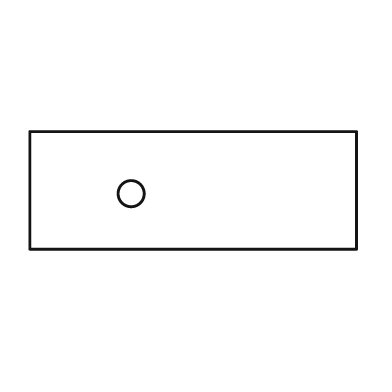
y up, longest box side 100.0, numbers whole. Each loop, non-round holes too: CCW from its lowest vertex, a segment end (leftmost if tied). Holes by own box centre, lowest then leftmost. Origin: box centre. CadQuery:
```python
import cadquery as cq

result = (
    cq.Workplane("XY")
    .moveTo(-50.0, -18.0)
    .lineTo(50.0, -18.0)
    .lineTo(50.0, 18.0)
    .lineTo(-50.0, 18.0)
    .close()
    .moveTo(-19.0, -1.0)
    .circle(4.0)
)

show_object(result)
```